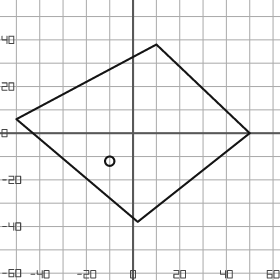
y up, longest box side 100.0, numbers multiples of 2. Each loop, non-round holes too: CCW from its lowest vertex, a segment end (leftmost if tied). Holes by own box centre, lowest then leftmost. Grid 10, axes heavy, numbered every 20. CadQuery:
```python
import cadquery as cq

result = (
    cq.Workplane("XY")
    .moveTo(2.0, -38.0)
    .lineTo(50.0, 0.0)
    .lineTo(10.0, 38.0)
    .lineTo(-50.0, 6.0)
    .close()
    .moveTo(-10.0, -12.0)
    .circle(2.0)
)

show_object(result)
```